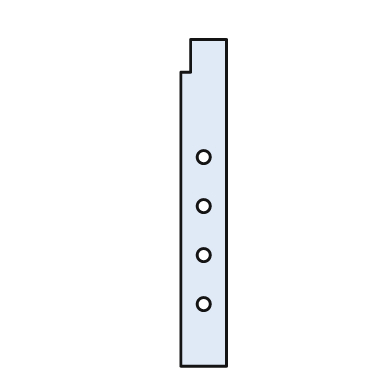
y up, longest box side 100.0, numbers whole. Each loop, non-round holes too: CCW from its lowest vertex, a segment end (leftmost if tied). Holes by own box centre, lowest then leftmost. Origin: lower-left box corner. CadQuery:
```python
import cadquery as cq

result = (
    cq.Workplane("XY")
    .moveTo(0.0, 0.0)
    .lineTo(14.0, 0.0)
    .lineTo(14.0, 100.0)
    .lineTo(3.0, 100.0)
    .lineTo(3.0, 90.0)
    .lineTo(0.0, 90.0)
    .close()
    .moveTo(7.0, 19.0)
    .circle(2.0)
    .moveTo(7.0, 34.0)
    .circle(2.0)
    .moveTo(7.0, 49.0)
    .circle(2.0)
    .moveTo(7.0, 64.0)
    .circle(2.0)
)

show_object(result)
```